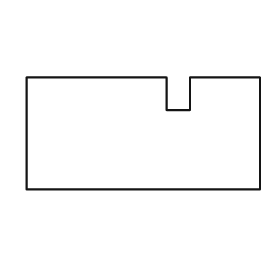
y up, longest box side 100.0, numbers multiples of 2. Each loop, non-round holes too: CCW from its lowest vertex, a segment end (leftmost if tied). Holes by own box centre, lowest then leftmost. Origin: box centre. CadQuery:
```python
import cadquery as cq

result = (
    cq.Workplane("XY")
    .moveTo(-50.0, -24.0)
    .lineTo(50.0, -24.0)
    .lineTo(50.0, 24.0)
    .lineTo(20.0, 24.0)
    .lineTo(20.0, 10.0)
    .lineTo(10.0, 10.0)
    .lineTo(10.0, 24.0)
    .lineTo(-50.0, 24.0)
    .close()
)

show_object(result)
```